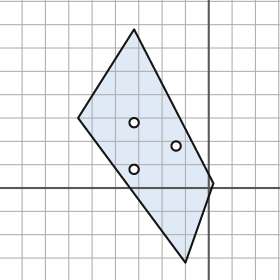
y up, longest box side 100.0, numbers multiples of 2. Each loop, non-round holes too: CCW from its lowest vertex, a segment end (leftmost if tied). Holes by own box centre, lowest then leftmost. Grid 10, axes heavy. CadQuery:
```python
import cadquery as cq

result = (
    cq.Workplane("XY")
    .moveTo(-10.0, -32.0)
    .lineTo(2.0, 2.0)
    .lineTo(-32.0, 68.0)
    .lineTo(-56.0, 30.0)
    .close()
    .moveTo(-32.0, 8.0)
    .circle(2.0)
    .moveTo(-14.0, 18.0)
    .circle(2.0)
    .moveTo(-32.0, 28.0)
    .circle(2.0)
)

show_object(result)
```